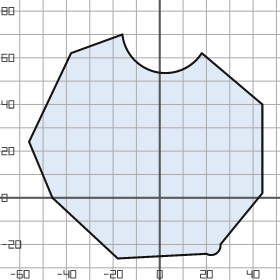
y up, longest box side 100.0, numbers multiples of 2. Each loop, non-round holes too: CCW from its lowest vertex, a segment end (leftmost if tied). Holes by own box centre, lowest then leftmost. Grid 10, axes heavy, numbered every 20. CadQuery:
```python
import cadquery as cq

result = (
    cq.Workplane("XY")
    .moveTo(-18.0, -26.0)
    .lineTo(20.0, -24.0)
    .threePointArc((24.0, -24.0), (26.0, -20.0))
    .lineTo(44.0, 2.0)
    .lineTo(44.0, 40.0)
    .lineTo(18.0, 62.0)
    .threePointArc((-2.0, 54.0), (-16.0, 70.0))
    .lineTo(-38.0, 62.0)
    .lineTo(-56.0, 24.0)
    .lineTo(-46.0, 0.0)
    .close()
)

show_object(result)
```